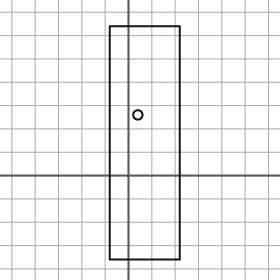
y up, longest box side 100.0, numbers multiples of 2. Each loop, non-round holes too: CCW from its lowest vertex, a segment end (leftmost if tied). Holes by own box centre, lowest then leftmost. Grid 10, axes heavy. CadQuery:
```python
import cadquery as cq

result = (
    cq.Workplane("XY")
    .moveTo(-8.0, -36.0)
    .lineTo(22.0, -36.0)
    .lineTo(22.0, 64.0)
    .lineTo(-8.0, 64.0)
    .close()
    .moveTo(4.0, 26.0)
    .circle(2.0)
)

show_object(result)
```